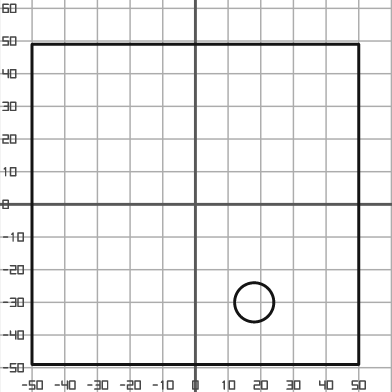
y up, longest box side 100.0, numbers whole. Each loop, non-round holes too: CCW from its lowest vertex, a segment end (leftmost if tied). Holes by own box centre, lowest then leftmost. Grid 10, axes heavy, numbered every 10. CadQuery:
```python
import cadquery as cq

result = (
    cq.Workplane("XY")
    .moveTo(-50.0, -49.0)
    .lineTo(50.0, -49.0)
    .lineTo(50.0, 49.0)
    .lineTo(-50.0, 49.0)
    .close()
    .moveTo(18.0, -30.0)
    .circle(6.0)
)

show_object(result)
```